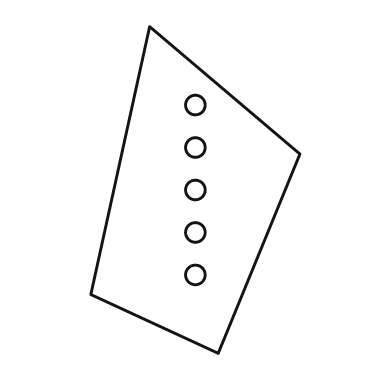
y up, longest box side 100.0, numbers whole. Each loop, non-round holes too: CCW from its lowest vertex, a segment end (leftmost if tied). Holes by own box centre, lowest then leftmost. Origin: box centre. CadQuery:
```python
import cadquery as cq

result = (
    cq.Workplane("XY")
    .moveTo(7.0, -50.0)
    .lineTo(32.0, 11.0)
    .lineTo(-14.0, 50.0)
    .lineTo(-32.0, -32.0)
    .close()
    .moveTo(0.0, -26.0)
    .circle(3.0)
    .moveTo(0.0, -13.0)
    .circle(3.0)
    .moveTo(0.0, 0.0)
    .circle(3.0)
    .moveTo(0.0, 13.0)
    .circle(3.0)
    .moveTo(0.0, 26.0)
    .circle(3.0)
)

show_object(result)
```